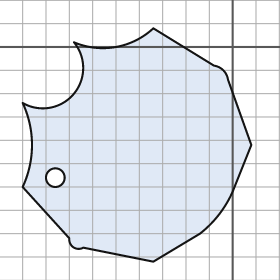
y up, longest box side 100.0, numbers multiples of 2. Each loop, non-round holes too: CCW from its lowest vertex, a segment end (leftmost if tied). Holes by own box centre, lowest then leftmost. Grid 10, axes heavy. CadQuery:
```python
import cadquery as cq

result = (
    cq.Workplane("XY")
    .moveTo(-34.0, -92.0)
    .lineTo(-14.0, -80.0)
    .threePointArc((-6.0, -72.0), (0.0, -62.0))
    .lineTo(8.0, -42.0)
    .lineTo(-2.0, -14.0)
    .threePointArc((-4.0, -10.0), (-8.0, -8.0))
    .lineTo(-34.0, 8.0)
    .threePointArc((-50.0, 0.0), (-68.0, 2.0))
    .threePointArc((-68.0, -20.0), (-90.0, -24.0))
    .threePointArc((-86.0, -42.0), (-90.0, -60.0))
    .lineTo(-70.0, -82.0)
    .threePointArc((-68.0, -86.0), (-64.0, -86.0))
    .close()
    .moveTo(-76.0, -56.0)
    .circle(4.0)
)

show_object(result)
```